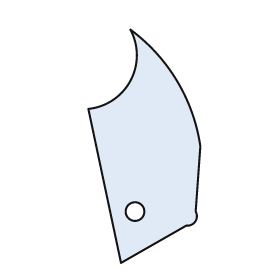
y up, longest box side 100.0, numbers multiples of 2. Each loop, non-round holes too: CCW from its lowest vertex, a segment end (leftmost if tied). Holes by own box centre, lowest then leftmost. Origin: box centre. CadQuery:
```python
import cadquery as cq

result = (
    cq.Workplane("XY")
    .moveTo(-10.0, -50.0)
    .lineTo(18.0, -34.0)
    .threePointArc((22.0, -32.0), (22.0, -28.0))
    .lineTo(24.0, 0.0)
    .threePointArc((14.0, 28.0), (-6.0, 50.0))
    .threePointArc((-6.0, 28.0), (-24.0, 16.0))
    .close()
    .moveTo(-4.0, -28.0)
    .circle(4.0)
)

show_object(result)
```